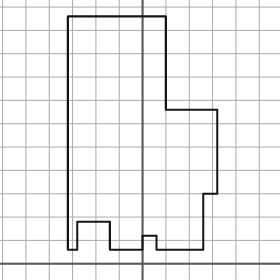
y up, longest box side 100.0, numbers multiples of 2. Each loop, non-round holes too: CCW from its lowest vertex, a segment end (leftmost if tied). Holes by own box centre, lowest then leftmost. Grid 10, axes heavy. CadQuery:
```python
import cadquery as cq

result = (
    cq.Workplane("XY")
    .moveTo(-32.0, 6.0)
    .lineTo(-28.0, 6.0)
    .lineTo(-28.0, 18.0)
    .lineTo(-14.0, 18.0)
    .lineTo(-14.0, 6.0)
    .lineTo(0.0, 6.0)
    .lineTo(0.0, 12.0)
    .lineTo(6.0, 12.0)
    .lineTo(6.0, 6.0)
    .lineTo(26.0, 6.0)
    .lineTo(26.0, 30.0)
    .lineTo(32.0, 30.0)
    .lineTo(32.0, 66.0)
    .lineTo(10.0, 66.0)
    .lineTo(10.0, 106.0)
    .lineTo(-32.0, 106.0)
    .close()
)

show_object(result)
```